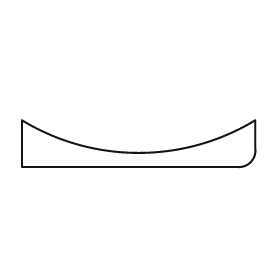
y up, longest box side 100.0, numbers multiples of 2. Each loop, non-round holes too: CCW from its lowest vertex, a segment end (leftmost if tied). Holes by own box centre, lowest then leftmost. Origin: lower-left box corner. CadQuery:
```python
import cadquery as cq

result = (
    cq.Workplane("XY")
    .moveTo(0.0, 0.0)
    .lineTo(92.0, 0.0)
    .threePointArc((98.0, 2.0), (100.0, 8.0))
    .lineTo(100.0, 20.0)
    .threePointArc((50.0, 6.0), (0.0, 20.0))
    .close()
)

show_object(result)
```